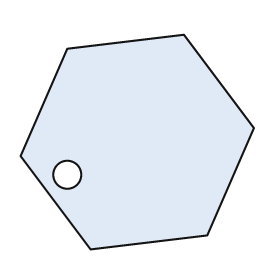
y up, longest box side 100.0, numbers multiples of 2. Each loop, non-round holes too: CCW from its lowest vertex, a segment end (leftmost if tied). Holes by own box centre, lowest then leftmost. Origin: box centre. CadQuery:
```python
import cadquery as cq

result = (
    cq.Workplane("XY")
    .moveTo(-20.0, -46.0)
    .lineTo(30.0, -40.0)
    .lineTo(50.0, 6.0)
    .lineTo(20.0, 46.0)
    .lineTo(-30.0, 40.0)
    .lineTo(-50.0, -6.0)
    .close()
    .moveTo(-30.0, -14.0)
    .circle(6.0)
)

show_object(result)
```